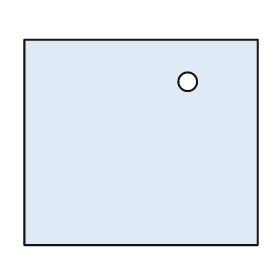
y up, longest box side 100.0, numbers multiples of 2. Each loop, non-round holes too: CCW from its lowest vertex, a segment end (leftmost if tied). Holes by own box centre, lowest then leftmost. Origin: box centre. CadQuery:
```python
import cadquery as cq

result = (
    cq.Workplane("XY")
    .moveTo(-50.0, -44.0)
    .lineTo(50.0, -44.0)
    .lineTo(50.0, 44.0)
    .lineTo(-50.0, 44.0)
    .close()
    .moveTo(20.0, 26.0)
    .circle(4.0)
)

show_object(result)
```